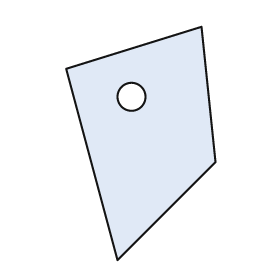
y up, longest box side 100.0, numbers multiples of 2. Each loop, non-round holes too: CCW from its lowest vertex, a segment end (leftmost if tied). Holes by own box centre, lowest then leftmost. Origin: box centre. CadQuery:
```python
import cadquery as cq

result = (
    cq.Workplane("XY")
    .moveTo(-10.0, -50.0)
    .lineTo(32.0, -8.0)
    .lineTo(26.0, 50.0)
    .lineTo(-32.0, 32.0)
    .close()
    .moveTo(-4.0, 20.0)
    .circle(6.0)
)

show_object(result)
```